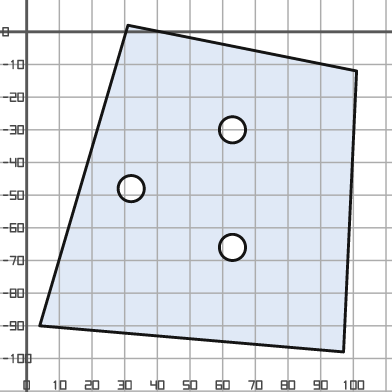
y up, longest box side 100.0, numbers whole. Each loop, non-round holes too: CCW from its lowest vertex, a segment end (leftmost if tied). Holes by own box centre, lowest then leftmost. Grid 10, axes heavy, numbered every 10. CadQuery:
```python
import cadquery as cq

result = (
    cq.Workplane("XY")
    .moveTo(97.0, -98.0)
    .lineTo(101.0, -12.0)
    .lineTo(31.0, 2.0)
    .lineTo(4.0, -90.0)
    .close()
    .moveTo(63.0, -66.0)
    .circle(4.0)
    .moveTo(32.0, -48.0)
    .circle(4.0)
    .moveTo(63.0, -30.0)
    .circle(4.0)
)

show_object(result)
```